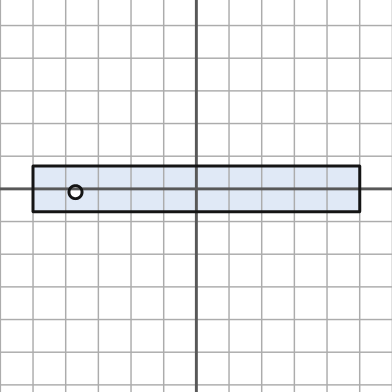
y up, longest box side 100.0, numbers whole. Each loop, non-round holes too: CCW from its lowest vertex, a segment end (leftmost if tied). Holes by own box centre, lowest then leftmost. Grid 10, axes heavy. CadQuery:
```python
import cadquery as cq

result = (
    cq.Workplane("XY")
    .moveTo(-50.0, -7.0)
    .lineTo(50.0, -7.0)
    .lineTo(50.0, 7.0)
    .lineTo(-50.0, 7.0)
    .close()
    .moveTo(-37.0, -1.0)
    .circle(2.0)
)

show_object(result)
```